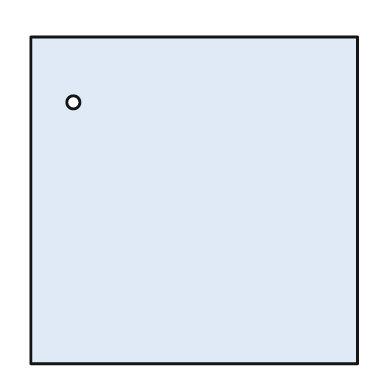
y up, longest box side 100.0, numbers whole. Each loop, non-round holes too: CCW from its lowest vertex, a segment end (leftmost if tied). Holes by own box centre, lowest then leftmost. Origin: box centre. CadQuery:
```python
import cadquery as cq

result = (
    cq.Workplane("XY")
    .moveTo(-50.0, -50.0)
    .lineTo(50.0, -50.0)
    .lineTo(50.0, 50.0)
    .lineTo(-50.0, 50.0)
    .close()
    .moveTo(-37.0, 30.0)
    .circle(2.0)
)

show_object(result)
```